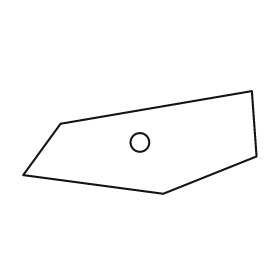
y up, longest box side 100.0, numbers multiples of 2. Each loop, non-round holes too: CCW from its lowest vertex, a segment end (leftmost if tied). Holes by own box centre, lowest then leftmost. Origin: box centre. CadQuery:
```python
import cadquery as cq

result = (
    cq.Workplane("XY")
    .moveTo(10.0, -22.0)
    .lineTo(50.0, -6.0)
    .lineTo(48.0, 22.0)
    .lineTo(-34.0, 8.0)
    .lineTo(-50.0, -14.0)
    .close()
    .moveTo(0.0, 0.0)
    .circle(4.0)
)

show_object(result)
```